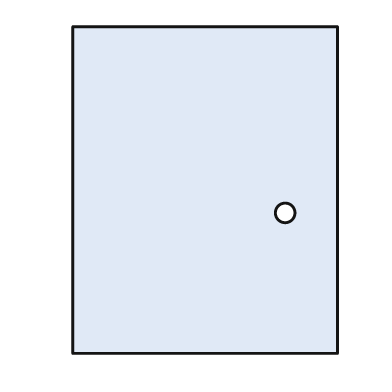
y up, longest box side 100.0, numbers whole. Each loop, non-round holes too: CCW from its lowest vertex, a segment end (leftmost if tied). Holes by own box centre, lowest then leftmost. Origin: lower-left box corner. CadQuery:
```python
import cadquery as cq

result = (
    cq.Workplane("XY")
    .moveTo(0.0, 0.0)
    .lineTo(81.0, 0.0)
    .lineTo(81.0, 100.0)
    .lineTo(0.0, 100.0)
    .close()
    .moveTo(65.0, 43.0)
    .circle(3.0)
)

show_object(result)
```